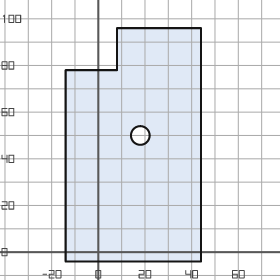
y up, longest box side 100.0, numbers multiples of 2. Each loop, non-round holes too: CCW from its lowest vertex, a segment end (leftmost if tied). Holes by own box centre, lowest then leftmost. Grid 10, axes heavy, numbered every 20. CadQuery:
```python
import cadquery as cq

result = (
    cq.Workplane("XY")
    .moveTo(-14.0, -4.0)
    .lineTo(44.0, -4.0)
    .lineTo(44.0, 96.0)
    .lineTo(8.0, 96.0)
    .lineTo(8.0, 78.0)
    .lineTo(-14.0, 78.0)
    .close()
    .moveTo(18.0, 50.0)
    .circle(4.0)
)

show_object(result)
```